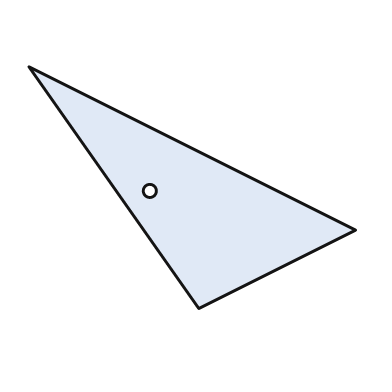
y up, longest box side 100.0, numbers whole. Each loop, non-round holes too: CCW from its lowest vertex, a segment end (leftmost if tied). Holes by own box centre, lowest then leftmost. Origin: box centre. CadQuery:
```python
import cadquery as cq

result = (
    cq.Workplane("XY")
    .moveTo(2.0, -37.0)
    .lineTo(50.0, -13.0)
    .lineTo(-50.0, 37.0)
    .close()
    .moveTo(-13.0, -1.0)
    .circle(2.0)
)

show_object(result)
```